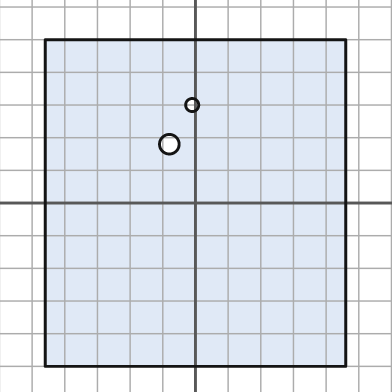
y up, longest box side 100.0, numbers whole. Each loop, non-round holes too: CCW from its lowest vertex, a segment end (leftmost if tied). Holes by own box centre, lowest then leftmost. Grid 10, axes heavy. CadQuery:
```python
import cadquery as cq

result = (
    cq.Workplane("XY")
    .moveTo(-46.0, -50.0)
    .lineTo(46.0, -50.0)
    .lineTo(46.0, 50.0)
    .lineTo(-46.0, 50.0)
    .close()
    .moveTo(-8.0, 18.0)
    .circle(3.0)
    .moveTo(-1.0, 30.0)
    .circle(2.0)
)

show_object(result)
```